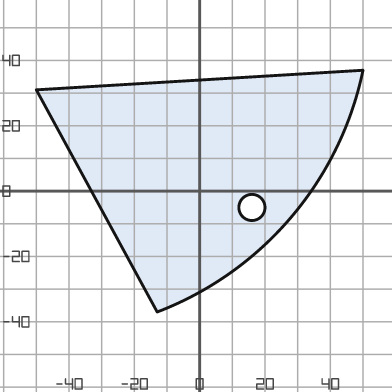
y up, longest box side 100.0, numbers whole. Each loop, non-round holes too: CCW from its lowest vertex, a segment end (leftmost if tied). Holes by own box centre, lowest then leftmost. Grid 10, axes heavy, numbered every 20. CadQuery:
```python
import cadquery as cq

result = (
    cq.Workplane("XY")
    .moveTo(-13.0, -37.0)
    .threePointArc((28.0, -8.0), (50.0, 37.0))
    .lineTo(-50.0, 31.0)
    .close()
    .moveTo(16.0, -5.0)
    .circle(4.0)
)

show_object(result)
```